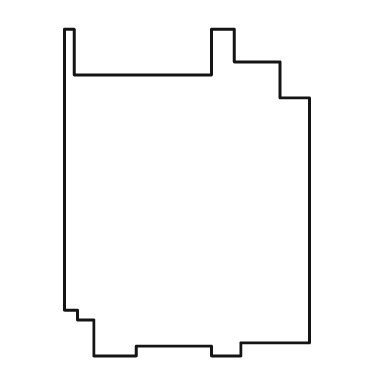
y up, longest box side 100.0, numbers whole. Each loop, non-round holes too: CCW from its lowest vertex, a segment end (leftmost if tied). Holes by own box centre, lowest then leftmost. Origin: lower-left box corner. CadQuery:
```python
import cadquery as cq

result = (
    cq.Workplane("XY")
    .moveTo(9.0, 0.0)
    .lineTo(22.0, 0.0)
    .lineTo(22.0, 3.0)
    .lineTo(45.0, 3.0)
    .lineTo(45.0, 0.0)
    .lineTo(54.0, 0.0)
    .lineTo(54.0, 4.0)
    .lineTo(75.0, 4.0)
    .lineTo(75.0, 79.0)
    .lineTo(66.0, 79.0)
    .lineTo(66.0, 90.0)
    .lineTo(52.0, 90.0)
    .lineTo(52.0, 100.0)
    .lineTo(45.0, 100.0)
    .lineTo(45.0, 86.0)
    .lineTo(3.0, 86.0)
    .lineTo(3.0, 100.0)
    .lineTo(0.0, 100.0)
    .lineTo(0.0, 14.0)
    .lineTo(4.0, 14.0)
    .lineTo(4.0, 11.0)
    .lineTo(9.0, 11.0)
    .close()
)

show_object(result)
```